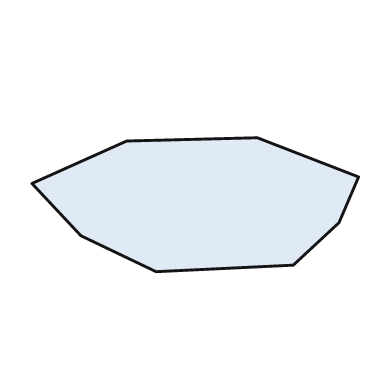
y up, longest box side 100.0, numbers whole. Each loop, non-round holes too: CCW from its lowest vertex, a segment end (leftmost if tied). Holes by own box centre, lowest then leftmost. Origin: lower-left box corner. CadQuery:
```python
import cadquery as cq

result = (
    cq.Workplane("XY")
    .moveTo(38.0, 0.0)
    .lineTo(80.0, 2.0)
    .lineTo(94.0, 15.0)
    .lineTo(100.0, 29.0)
    .lineTo(69.0, 41.0)
    .lineTo(29.0, 40.0)
    .lineTo(0.0, 27.0)
    .lineTo(15.0, 11.0)
    .close()
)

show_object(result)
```